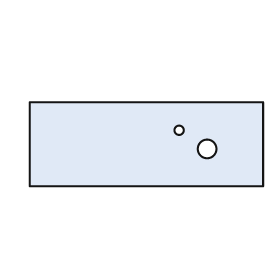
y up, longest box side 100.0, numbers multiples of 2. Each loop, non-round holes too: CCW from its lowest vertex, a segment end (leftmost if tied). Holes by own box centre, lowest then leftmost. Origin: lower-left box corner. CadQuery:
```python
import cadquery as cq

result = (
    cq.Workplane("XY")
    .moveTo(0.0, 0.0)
    .lineTo(100.0, 0.0)
    .lineTo(100.0, 36.0)
    .lineTo(0.0, 36.0)
    .close()
    .moveTo(76.0, 16.0)
    .circle(4.0)
    .moveTo(64.0, 24.0)
    .circle(2.0)
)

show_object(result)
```